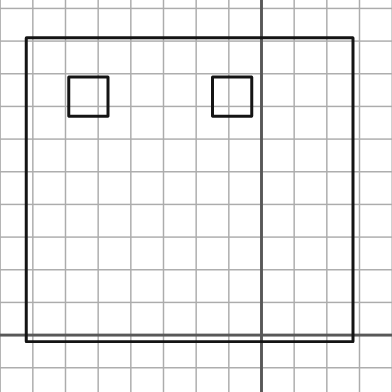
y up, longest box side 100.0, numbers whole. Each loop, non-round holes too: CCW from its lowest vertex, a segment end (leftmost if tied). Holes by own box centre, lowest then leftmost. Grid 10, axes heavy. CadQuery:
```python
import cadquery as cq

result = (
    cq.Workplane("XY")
    .moveTo(-72.0, -2.0)
    .lineTo(28.0, -2.0)
    .lineTo(28.0, 91.0)
    .lineTo(-72.0, 91.0)
    .close()
    .moveTo(-59.0, 67.0)
    .lineTo(-47.0, 67.0)
    .lineTo(-47.0, 79.0)
    .lineTo(-59.0, 79.0)
    .close()
    .moveTo(-15.0, 67.0)
    .lineTo(-3.0, 67.0)
    .lineTo(-3.0, 79.0)
    .lineTo(-15.0, 79.0)
    .close()
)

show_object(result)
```